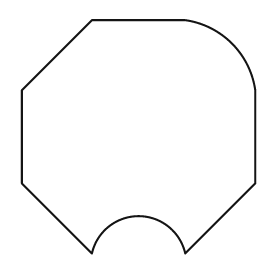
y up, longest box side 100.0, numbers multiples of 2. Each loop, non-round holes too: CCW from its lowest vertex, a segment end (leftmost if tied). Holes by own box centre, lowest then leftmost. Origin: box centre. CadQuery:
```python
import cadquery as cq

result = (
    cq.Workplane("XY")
    .moveTo(-20.0, -50.0)
    .threePointArc((0.0, -34.0), (20.0, -50.0))
    .lineTo(50.0, -20.0)
    .lineTo(50.0, 20.0)
    .threePointArc((40.0, 40.0), (20.0, 50.0))
    .lineTo(-20.0, 50.0)
    .lineTo(-50.0, 20.0)
    .lineTo(-50.0, -20.0)
    .close()
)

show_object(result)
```